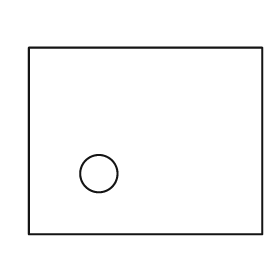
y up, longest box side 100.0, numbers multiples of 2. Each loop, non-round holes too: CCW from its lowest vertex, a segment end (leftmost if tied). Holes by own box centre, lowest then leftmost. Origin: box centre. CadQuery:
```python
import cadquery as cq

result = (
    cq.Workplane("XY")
    .moveTo(-50.0, -40.0)
    .lineTo(50.0, -40.0)
    .lineTo(50.0, 40.0)
    .lineTo(-50.0, 40.0)
    .close()
    .moveTo(-20.0, -14.0)
    .circle(8.0)
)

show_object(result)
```